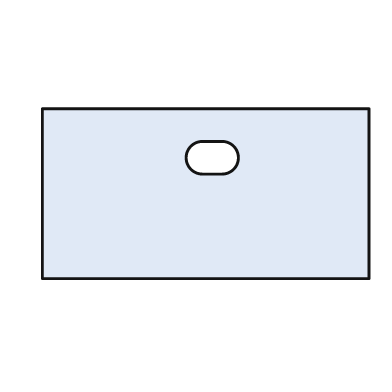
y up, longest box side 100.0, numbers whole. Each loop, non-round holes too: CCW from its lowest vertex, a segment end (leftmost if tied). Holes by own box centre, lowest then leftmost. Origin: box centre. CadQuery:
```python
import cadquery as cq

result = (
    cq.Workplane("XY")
    .moveTo(-50.0, -26.0)
    .lineTo(50.0, -26.0)
    .lineTo(50.0, 26.0)
    .lineTo(-50.0, 26.0)
    .close()
    .moveTo(-1.0, 6.0)
    .lineTo(5.0, 6.0)
    .threePointArc((10.0, 11.0), (5.0, 16.0))
    .lineTo(-1.0, 16.0)
    .threePointArc((-6.0, 11.0), (-1.0, 6.0))
    .close()
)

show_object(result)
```